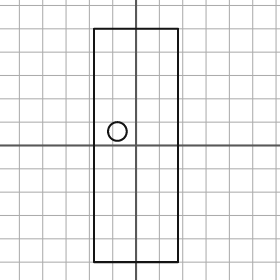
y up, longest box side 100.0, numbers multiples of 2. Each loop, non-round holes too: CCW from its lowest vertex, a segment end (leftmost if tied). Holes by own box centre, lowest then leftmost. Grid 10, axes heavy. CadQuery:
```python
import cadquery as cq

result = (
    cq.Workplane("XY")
    .moveTo(-18.0, -50.0)
    .lineTo(18.0, -50.0)
    .lineTo(18.0, 50.0)
    .lineTo(-18.0, 50.0)
    .close()
    .moveTo(-8.0, 6.0)
    .circle(4.0)
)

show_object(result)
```